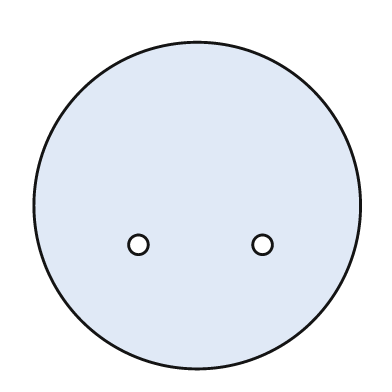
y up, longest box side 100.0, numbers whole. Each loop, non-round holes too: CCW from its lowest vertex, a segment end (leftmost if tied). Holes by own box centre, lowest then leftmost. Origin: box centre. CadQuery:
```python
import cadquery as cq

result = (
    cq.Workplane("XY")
    .moveTo(0.0, 0.0)
    .circle(50.0)
    .moveTo(-18.0, -12.0)
    .circle(3.0)
    .moveTo(20.0, -12.0)
    .circle(3.0)
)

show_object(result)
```